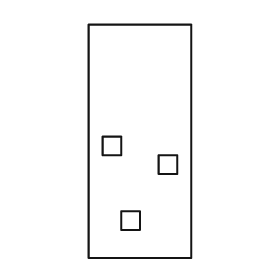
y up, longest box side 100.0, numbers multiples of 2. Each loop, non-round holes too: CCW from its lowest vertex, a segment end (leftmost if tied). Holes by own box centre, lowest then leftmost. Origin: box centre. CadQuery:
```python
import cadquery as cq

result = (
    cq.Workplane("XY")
    .moveTo(-22.0, -50.0)
    .lineTo(22.0, -50.0)
    .lineTo(22.0, 50.0)
    .lineTo(-22.0, 50.0)
    .close()
    .moveTo(-8.0, -38.0)
    .lineTo(0.0, -38.0)
    .lineTo(0.0, -30.0)
    .lineTo(-8.0, -30.0)
    .close()
    .moveTo(8.0, -14.0)
    .lineTo(16.0, -14.0)
    .lineTo(16.0, -6.0)
    .lineTo(8.0, -6.0)
    .close()
    .moveTo(-16.0, -6.0)
    .lineTo(-8.0, -6.0)
    .lineTo(-8.0, 2.0)
    .lineTo(-16.0, 2.0)
    .close()
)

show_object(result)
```